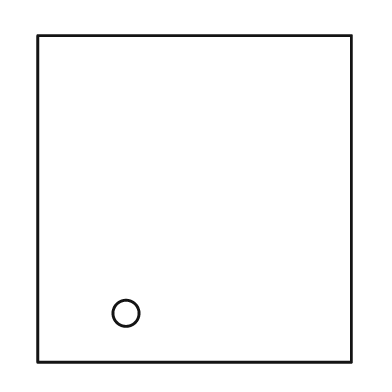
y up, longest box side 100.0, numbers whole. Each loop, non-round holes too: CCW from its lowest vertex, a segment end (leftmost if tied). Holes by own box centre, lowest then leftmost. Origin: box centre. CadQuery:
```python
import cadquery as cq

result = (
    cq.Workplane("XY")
    .moveTo(-48.0, -50.0)
    .lineTo(48.0, -50.0)
    .lineTo(48.0, 50.0)
    .lineTo(-48.0, 50.0)
    .close()
    .moveTo(-21.0, -35.0)
    .circle(4.0)
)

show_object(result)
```